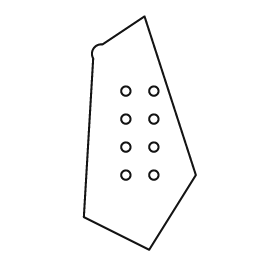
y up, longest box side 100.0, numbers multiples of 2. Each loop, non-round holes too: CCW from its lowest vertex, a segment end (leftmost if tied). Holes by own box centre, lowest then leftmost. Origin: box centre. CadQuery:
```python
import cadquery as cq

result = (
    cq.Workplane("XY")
    .moveTo(4.0, -50.0)
    .lineTo(24.0, -18.0)
    .lineTo(2.0, 50.0)
    .lineTo(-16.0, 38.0)
    .threePointArc((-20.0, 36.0), (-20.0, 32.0))
    .lineTo(-24.0, -36.0)
    .close()
    .moveTo(-6.0, -18.0)
    .circle(2.0)
    .moveTo(6.0, -18.0)
    .circle(2.0)
    .moveTo(-6.0, -6.0)
    .circle(2.0)
    .moveTo(6.0, -6.0)
    .circle(2.0)
    .moveTo(-6.0, 6.0)
    .circle(2.0)
    .moveTo(6.0, 6.0)
    .circle(2.0)
    .moveTo(-6.0, 18.0)
    .circle(2.0)
    .moveTo(6.0, 18.0)
    .circle(2.0)
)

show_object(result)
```